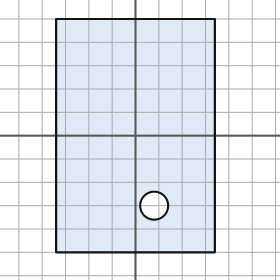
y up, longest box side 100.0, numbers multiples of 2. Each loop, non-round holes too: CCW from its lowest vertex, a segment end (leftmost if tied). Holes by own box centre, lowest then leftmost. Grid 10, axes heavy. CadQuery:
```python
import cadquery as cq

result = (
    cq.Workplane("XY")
    .moveTo(-34.0, -50.0)
    .lineTo(34.0, -50.0)
    .lineTo(34.0, 50.0)
    .lineTo(-34.0, 50.0)
    .close()
    .moveTo(8.0, -30.0)
    .circle(6.0)
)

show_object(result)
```